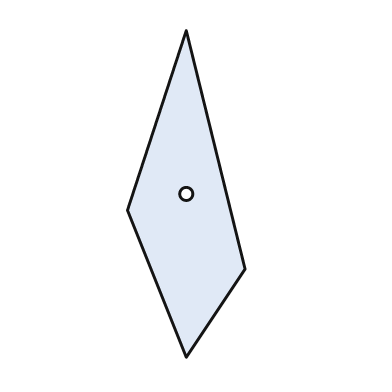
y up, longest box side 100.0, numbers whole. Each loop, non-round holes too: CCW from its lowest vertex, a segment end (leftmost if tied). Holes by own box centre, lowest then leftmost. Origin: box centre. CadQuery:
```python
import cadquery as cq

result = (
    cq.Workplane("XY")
    .moveTo(0.0, -50.0)
    .lineTo(18.0, -23.0)
    .lineTo(0.0, 50.0)
    .lineTo(-18.0, -5.0)
    .close()
    .moveTo(0.0, 0.0)
    .circle(2.0)
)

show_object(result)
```